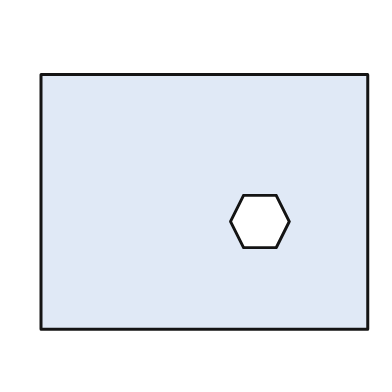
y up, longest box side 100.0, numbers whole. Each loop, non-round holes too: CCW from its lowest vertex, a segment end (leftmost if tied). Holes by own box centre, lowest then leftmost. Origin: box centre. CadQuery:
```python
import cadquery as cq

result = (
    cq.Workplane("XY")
    .moveTo(-50.0, -39.0)
    .lineTo(50.0, -39.0)
    .lineTo(50.0, 39.0)
    .lineTo(-50.0, 39.0)
    .close()
    .moveTo(12.0, -14.0)
    .lineTo(22.0, -14.0)
    .lineTo(26.0, -6.0)
    .lineTo(22.0, 2.0)
    .lineTo(12.0, 2.0)
    .lineTo(8.0, -6.0)
    .close()
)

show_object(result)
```